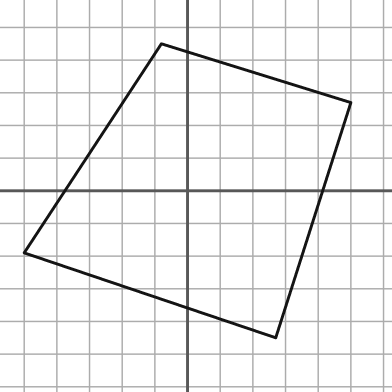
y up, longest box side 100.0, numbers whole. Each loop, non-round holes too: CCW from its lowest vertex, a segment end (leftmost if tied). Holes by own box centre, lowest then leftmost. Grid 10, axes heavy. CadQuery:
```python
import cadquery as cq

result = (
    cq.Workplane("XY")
    .moveTo(27.0, -45.0)
    .lineTo(50.0, 27.0)
    .lineTo(-8.0, 45.0)
    .lineTo(-50.0, -19.0)
    .close()
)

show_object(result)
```